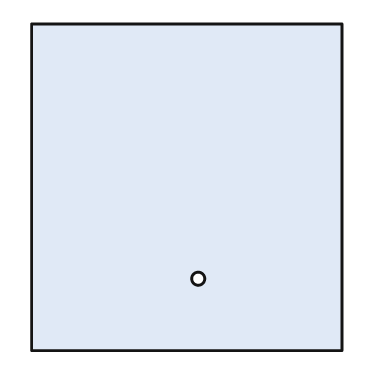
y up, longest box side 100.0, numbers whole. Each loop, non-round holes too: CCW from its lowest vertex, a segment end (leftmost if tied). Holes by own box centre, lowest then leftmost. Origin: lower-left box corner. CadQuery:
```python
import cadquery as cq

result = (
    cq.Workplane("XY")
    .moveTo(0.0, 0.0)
    .lineTo(95.0, 0.0)
    .lineTo(95.0, 100.0)
    .lineTo(0.0, 100.0)
    .close()
    .moveTo(51.0, 22.0)
    .circle(2.0)
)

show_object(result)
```